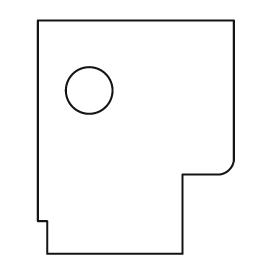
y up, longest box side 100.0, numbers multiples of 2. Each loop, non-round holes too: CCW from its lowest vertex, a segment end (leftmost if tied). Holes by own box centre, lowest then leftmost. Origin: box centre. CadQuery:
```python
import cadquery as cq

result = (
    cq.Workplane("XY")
    .moveTo(-38.0, -50.0)
    .lineTo(20.0, -50.0)
    .lineTo(20.0, -16.0)
    .lineTo(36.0, -16.0)
    .threePointArc((40.0, -14.0), (42.0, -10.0))
    .lineTo(42.0, 50.0)
    .lineTo(-42.0, 50.0)
    .lineTo(-42.0, -36.0)
    .lineTo(-38.0, -36.0)
    .close()
    .moveTo(-20.0, 20.0)
    .circle(10.0)
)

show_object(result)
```